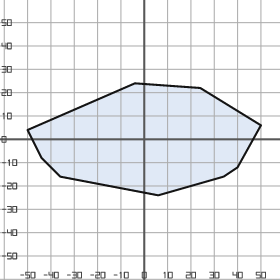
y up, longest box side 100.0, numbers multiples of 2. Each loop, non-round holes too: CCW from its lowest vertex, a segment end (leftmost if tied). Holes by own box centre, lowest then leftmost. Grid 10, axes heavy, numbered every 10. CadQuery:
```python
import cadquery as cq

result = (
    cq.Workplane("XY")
    .moveTo(6.0, -24.0)
    .lineTo(34.0, -16.0)
    .lineTo(40.0, -12.0)
    .lineTo(50.0, 6.0)
    .lineTo(24.0, 22.0)
    .lineTo(-4.0, 24.0)
    .lineTo(-50.0, 4.0)
    .lineTo(-44.0, -8.0)
    .lineTo(-36.0, -16.0)
    .close()
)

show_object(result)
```